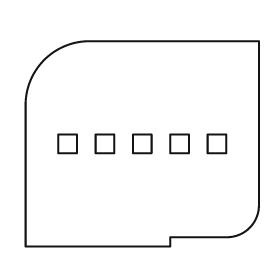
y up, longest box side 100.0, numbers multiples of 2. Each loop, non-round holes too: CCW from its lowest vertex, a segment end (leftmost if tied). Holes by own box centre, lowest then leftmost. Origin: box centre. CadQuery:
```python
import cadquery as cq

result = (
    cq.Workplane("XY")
    .moveTo(-50.0, -44.0)
    .lineTo(12.0, -44.0)
    .lineTo(12.0, -40.0)
    .lineTo(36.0, -40.0)
    .threePointArc((46.0, -36.0), (50.0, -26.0))
    .lineTo(50.0, 44.0)
    .lineTo(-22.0, 44.0)
    .threePointArc((-42.0, 36.0), (-50.0, 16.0))
    .close()
    .moveTo(-36.0, -4.0)
    .lineTo(-28.0, -4.0)
    .lineTo(-28.0, 4.0)
    .lineTo(-36.0, 4.0)
    .close()
    .moveTo(-20.0, -4.0)
    .lineTo(-12.0, -4.0)
    .lineTo(-12.0, 4.0)
    .lineTo(-20.0, 4.0)
    .close()
    .moveTo(-4.0, -4.0)
    .lineTo(4.0, -4.0)
    .lineTo(4.0, 4.0)
    .lineTo(-4.0, 4.0)
    .close()
    .moveTo(12.0, -4.0)
    .lineTo(20.0, -4.0)
    .lineTo(20.0, 4.0)
    .lineTo(12.0, 4.0)
    .close()
    .moveTo(28.0, -4.0)
    .lineTo(36.0, -4.0)
    .lineTo(36.0, 4.0)
    .lineTo(28.0, 4.0)
    .close()
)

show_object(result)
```